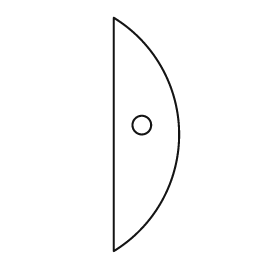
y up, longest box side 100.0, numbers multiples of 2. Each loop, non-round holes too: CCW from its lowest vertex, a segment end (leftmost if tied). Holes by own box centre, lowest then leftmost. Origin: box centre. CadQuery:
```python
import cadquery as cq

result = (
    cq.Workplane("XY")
    .moveTo(-14.0, -50.0)
    .threePointArc((14.0, 0.0), (-14.0, 50.0))
    .close()
    .moveTo(-2.0, 4.0)
    .circle(4.0)
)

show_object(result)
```